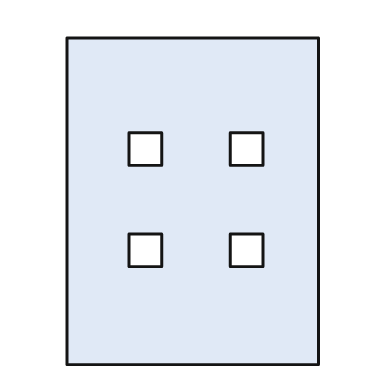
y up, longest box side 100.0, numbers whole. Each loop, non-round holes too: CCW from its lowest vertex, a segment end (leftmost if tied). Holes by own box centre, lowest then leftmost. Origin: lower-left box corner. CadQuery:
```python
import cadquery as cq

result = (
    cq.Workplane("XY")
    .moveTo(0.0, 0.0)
    .lineTo(77.0, 0.0)
    .lineTo(77.0, 100.0)
    .lineTo(0.0, 100.0)
    .close()
    .moveTo(19.0, 30.0)
    .lineTo(29.0, 30.0)
    .lineTo(29.0, 40.0)
    .lineTo(19.0, 40.0)
    .close()
    .moveTo(50.0, 30.0)
    .lineTo(60.0, 30.0)
    .lineTo(60.0, 40.0)
    .lineTo(50.0, 40.0)
    .close()
    .moveTo(19.0, 61.0)
    .lineTo(29.0, 61.0)
    .lineTo(29.0, 71.0)
    .lineTo(19.0, 71.0)
    .close()
    .moveTo(50.0, 61.0)
    .lineTo(60.0, 61.0)
    .lineTo(60.0, 71.0)
    .lineTo(50.0, 71.0)
    .close()
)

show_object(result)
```